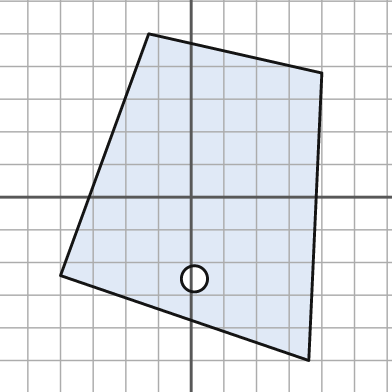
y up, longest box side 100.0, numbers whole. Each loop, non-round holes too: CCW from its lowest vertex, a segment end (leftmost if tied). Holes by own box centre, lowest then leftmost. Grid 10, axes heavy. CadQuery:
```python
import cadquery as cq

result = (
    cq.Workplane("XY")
    .moveTo(36.0, -50.0)
    .lineTo(40.0, 38.0)
    .lineTo(-13.0, 50.0)
    .lineTo(-40.0, -24.0)
    .close()
    .moveTo(1.0, -25.0)
    .circle(4.0)
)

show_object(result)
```